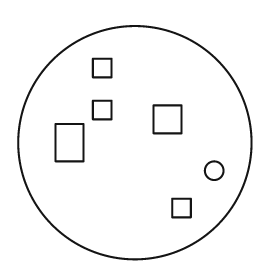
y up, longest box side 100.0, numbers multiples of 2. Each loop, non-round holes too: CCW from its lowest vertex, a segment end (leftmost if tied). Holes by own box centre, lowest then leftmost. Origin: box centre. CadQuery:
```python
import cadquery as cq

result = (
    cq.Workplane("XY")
    .moveTo(0.0, 0.0)
    .circle(50.0)
    .moveTo(16.0, -32.0)
    .lineTo(24.0, -32.0)
    .lineTo(24.0, -24.0)
    .lineTo(16.0, -24.0)
    .close()
    .moveTo(34.0, -12.0)
    .circle(4.0)
    .moveTo(-34.0, -8.0)
    .lineTo(-22.0, -8.0)
    .lineTo(-22.0, 8.0)
    .lineTo(-34.0, 8.0)
    .close()
    .moveTo(8.0, 4.0)
    .lineTo(20.0, 4.0)
    .lineTo(20.0, 16.0)
    .lineTo(8.0, 16.0)
    .close()
    .moveTo(-18.0, 10.0)
    .lineTo(-10.0, 10.0)
    .lineTo(-10.0, 18.0)
    .lineTo(-18.0, 18.0)
    .close()
    .moveTo(-18.0, 28.0)
    .lineTo(-10.0, 28.0)
    .lineTo(-10.0, 36.0)
    .lineTo(-18.0, 36.0)
    .close()
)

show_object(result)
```